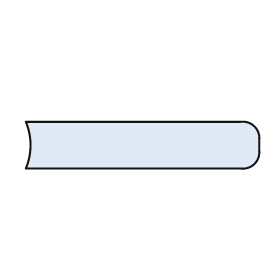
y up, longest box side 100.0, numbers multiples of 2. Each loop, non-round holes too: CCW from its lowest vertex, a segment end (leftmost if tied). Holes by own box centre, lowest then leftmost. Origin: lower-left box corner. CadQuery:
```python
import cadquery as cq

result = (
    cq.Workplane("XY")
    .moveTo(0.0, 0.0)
    .lineTo(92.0, 0.0)
    .threePointArc((98.0, 2.0), (100.0, 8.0))
    .lineTo(100.0, 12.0)
    .threePointArc((98.0, 18.0), (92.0, 20.0))
    .lineTo(0.0, 20.0)
    .threePointArc((2.0, 10.0), (0.0, 0.0))
    .close()
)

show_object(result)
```